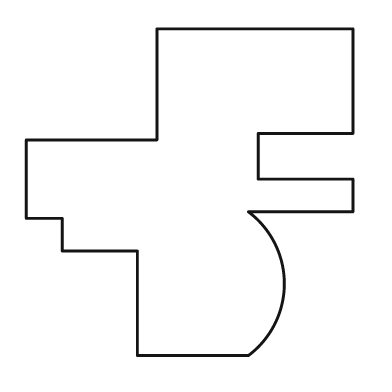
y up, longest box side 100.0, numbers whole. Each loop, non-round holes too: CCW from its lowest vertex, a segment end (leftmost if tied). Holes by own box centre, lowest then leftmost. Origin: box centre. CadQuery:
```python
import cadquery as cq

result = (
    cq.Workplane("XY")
    .moveTo(-16.0, -50.0)
    .lineTo(18.0, -50.0)
    .threePointArc((29.0, -28.0), (18.0, -6.0))
    .lineTo(50.0, -6.0)
    .lineTo(50.0, 4.0)
    .lineTo(21.0, 4.0)
    .lineTo(21.0, 18.0)
    .lineTo(50.0, 18.0)
    .lineTo(50.0, 50.0)
    .lineTo(-10.0, 50.0)
    .lineTo(-10.0, 16.0)
    .lineTo(-50.0, 16.0)
    .lineTo(-50.0, -8.0)
    .lineTo(-39.0, -8.0)
    .lineTo(-39.0, -18.0)
    .lineTo(-16.0, -18.0)
    .close()
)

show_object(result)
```